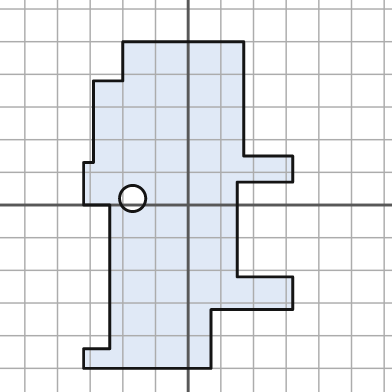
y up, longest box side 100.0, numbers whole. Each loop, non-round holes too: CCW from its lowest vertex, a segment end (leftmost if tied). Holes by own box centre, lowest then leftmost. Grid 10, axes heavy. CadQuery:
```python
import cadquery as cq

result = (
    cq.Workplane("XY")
    .moveTo(-32.0, -50.0)
    .lineTo(7.0, -50.0)
    .lineTo(7.0, -32.0)
    .lineTo(32.0, -32.0)
    .lineTo(32.0, -22.0)
    .lineTo(15.0, -22.0)
    .lineTo(15.0, 7.0)
    .lineTo(32.0, 7.0)
    .lineTo(32.0, 15.0)
    .lineTo(17.0, 15.0)
    .lineTo(17.0, 50.0)
    .lineTo(-20.0, 50.0)
    .lineTo(-20.0, 38.0)
    .lineTo(-29.0, 38.0)
    .lineTo(-29.0, 13.0)
    .lineTo(-32.0, 13.0)
    .lineTo(-32.0, 0.0)
    .lineTo(-24.0, 0.0)
    .lineTo(-24.0, -44.0)
    .lineTo(-32.0, -44.0)
    .close()
    .moveTo(-17.0, 2.0)
    .circle(4.0)
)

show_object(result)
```